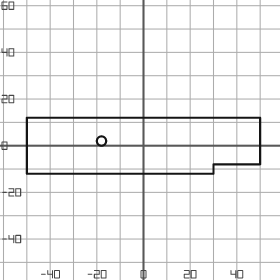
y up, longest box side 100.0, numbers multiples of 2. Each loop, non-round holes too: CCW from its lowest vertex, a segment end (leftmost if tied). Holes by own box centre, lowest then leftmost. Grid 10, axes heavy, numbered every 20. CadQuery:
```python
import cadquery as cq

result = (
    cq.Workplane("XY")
    .moveTo(-50.0, -12.0)
    .lineTo(30.0, -12.0)
    .lineTo(30.0, -8.0)
    .lineTo(50.0, -8.0)
    .lineTo(50.0, 12.0)
    .lineTo(-50.0, 12.0)
    .close()
    .moveTo(-18.0, 2.0)
    .circle(2.0)
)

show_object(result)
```